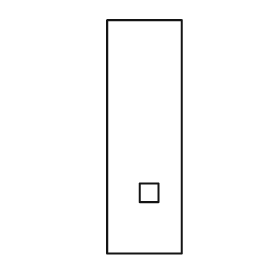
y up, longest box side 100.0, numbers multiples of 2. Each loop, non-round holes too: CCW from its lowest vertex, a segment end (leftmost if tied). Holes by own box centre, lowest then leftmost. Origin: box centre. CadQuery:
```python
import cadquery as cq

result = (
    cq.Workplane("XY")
    .moveTo(-16.0, -50.0)
    .lineTo(16.0, -50.0)
    .lineTo(16.0, 50.0)
    .lineTo(-16.0, 50.0)
    .close()
    .moveTo(-2.0, -28.0)
    .lineTo(6.0, -28.0)
    .lineTo(6.0, -20.0)
    .lineTo(-2.0, -20.0)
    .close()
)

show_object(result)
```